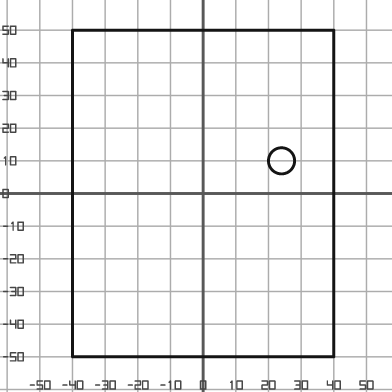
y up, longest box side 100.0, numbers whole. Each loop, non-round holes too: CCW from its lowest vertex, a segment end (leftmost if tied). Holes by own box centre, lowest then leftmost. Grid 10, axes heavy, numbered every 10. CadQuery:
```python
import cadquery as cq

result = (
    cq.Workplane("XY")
    .moveTo(-40.0, -50.0)
    .lineTo(40.0, -50.0)
    .lineTo(40.0, 50.0)
    .lineTo(-40.0, 50.0)
    .close()
    .moveTo(24.0, 10.0)
    .circle(4.0)
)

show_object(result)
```